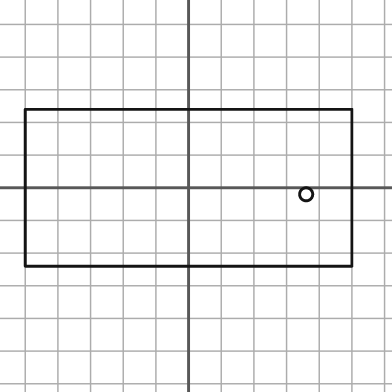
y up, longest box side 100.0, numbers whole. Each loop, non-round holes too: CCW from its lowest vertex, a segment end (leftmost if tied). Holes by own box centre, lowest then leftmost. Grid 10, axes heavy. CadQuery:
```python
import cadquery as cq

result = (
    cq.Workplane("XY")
    .moveTo(-50.0, -24.0)
    .lineTo(50.0, -24.0)
    .lineTo(50.0, 24.0)
    .lineTo(-50.0, 24.0)
    .close()
    .moveTo(36.0, -2.0)
    .circle(2.0)
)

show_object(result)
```